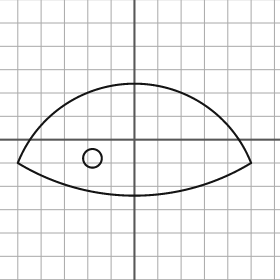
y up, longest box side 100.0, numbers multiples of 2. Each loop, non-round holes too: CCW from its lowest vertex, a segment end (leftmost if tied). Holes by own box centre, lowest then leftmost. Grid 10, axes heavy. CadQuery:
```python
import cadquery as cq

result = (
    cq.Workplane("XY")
    .moveTo(-50.0, -10.0)
    .threePointArc((0.0, -24.0), (50.0, -10.0))
    .threePointArc((0.0, 24.0), (-50.0, -10.0))
    .close()
    .moveTo(-18.0, -8.0)
    .circle(4.0)
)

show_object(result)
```